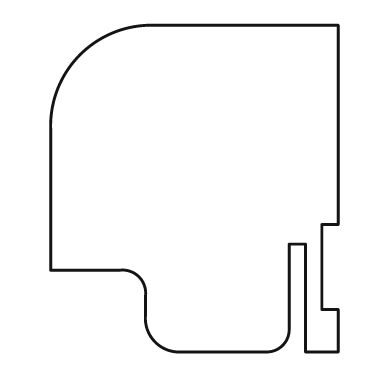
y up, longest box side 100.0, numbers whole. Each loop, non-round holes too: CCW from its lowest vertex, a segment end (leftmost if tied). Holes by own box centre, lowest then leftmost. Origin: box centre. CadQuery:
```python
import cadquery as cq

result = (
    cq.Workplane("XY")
    .moveTo(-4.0, -50.0)
    .lineTo(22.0, -50.0)
    .threePointArc((27.0, -48.0), (29.0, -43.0))
    .lineTo(29.0, -17.0)
    .lineTo(34.0, -17.0)
    .lineTo(34.0, -50.0)
    .lineTo(44.0, -50.0)
    .lineTo(44.0, -37.0)
    .lineTo(39.0, -37.0)
    .lineTo(39.0, -11.0)
    .lineTo(44.0, -11.0)
    .lineTo(44.0, 50.0)
    .lineTo(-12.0, 50.0)
    .threePointArc((-35.0, 41.0), (-44.0, 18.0))
    .lineTo(-44.0, -25.0)
    .lineTo(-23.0, -25.0)
    .threePointArc((-17.0, -27.0), (-15.0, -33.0))
    .lineTo(-15.0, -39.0)
    .threePointArc((-12.0, -47.0), (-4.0, -50.0))
    .close()
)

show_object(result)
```